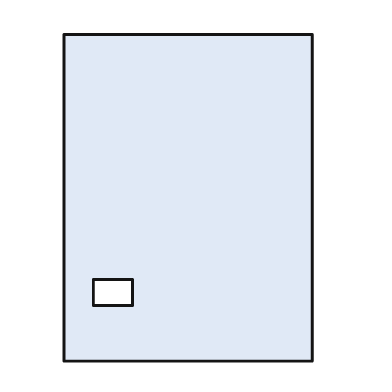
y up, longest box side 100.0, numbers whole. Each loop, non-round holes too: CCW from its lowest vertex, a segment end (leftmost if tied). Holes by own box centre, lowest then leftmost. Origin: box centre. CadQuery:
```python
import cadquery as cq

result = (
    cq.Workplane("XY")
    .moveTo(-38.0, -50.0)
    .lineTo(38.0, -50.0)
    .lineTo(38.0, 50.0)
    .lineTo(-38.0, 50.0)
    .close()
    .moveTo(-29.0, -33.0)
    .lineTo(-17.0, -33.0)
    .lineTo(-17.0, -25.0)
    .lineTo(-29.0, -25.0)
    .close()
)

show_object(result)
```